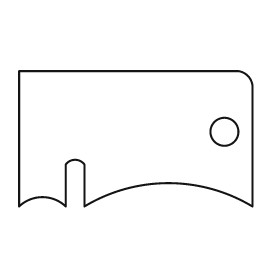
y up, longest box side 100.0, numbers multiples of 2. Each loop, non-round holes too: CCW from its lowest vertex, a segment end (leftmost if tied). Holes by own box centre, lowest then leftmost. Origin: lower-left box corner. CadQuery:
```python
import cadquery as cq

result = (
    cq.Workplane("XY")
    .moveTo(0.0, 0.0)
    .threePointArc((10.0, 4.0), (20.0, 0.0))
    .lineTo(20.0, 18.0)
    .threePointArc((24.0, 20.0), (28.0, 18.0))
    .lineTo(28.0, 0.0)
    .threePointArc((64.0, 10.0), (100.0, 0.0))
    .lineTo(100.0, 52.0)
    .threePointArc((98.0, 56.0), (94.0, 58.0))
    .lineTo(0.0, 58.0)
    .close()
    .moveTo(88.0, 32.0)
    .circle(6.0)
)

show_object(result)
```